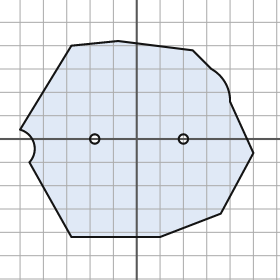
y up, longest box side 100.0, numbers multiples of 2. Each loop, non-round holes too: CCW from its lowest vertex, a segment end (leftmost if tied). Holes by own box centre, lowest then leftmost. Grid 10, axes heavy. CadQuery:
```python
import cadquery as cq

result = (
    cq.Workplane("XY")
    .moveTo(-28.0, -42.0)
    .lineTo(10.0, -42.0)
    .lineTo(36.0, -32.0)
    .lineTo(50.0, -6.0)
    .lineTo(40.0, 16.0)
    .threePointArc((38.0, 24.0), (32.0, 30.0))
    .lineTo(24.0, 38.0)
    .lineTo(-8.0, 42.0)
    .lineTo(-28.0, 40.0)
    .lineTo(-50.0, 4.0)
    .threePointArc((-44.0, -2.0), (-46.0, -10.0))
    .close()
    .moveTo(-18.0, 0.0)
    .circle(2.0)
    .moveTo(20.0, 0.0)
    .circle(2.0)
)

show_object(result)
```